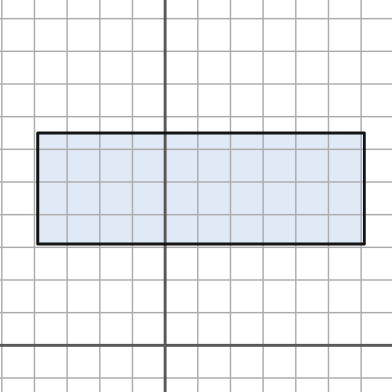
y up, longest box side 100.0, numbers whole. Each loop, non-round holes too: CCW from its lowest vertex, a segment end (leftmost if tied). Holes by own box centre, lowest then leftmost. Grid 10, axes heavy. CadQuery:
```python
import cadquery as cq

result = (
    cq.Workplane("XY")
    .moveTo(-39.0, 31.0)
    .lineTo(61.0, 31.0)
    .lineTo(61.0, 65.0)
    .lineTo(-39.0, 65.0)
    .close()
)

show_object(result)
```